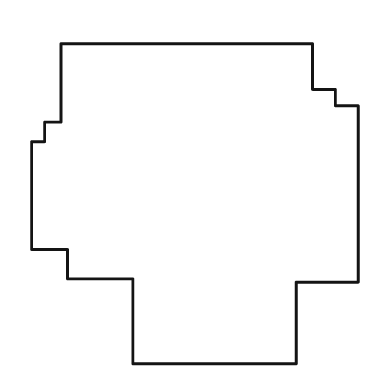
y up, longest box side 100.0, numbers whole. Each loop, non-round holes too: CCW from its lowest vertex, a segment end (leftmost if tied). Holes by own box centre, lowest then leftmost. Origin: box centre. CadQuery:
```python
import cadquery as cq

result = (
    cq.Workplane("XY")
    .moveTo(-19.0, -49.0)
    .lineTo(31.0, -49.0)
    .lineTo(31.0, -24.0)
    .lineTo(50.0, -24.0)
    .lineTo(50.0, 30.0)
    .lineTo(43.0, 30.0)
    .lineTo(43.0, 35.0)
    .lineTo(36.0, 35.0)
    .lineTo(36.0, 49.0)
    .lineTo(-41.0, 49.0)
    .lineTo(-41.0, 25.0)
    .lineTo(-46.0, 25.0)
    .lineTo(-46.0, 19.0)
    .lineTo(-50.0, 19.0)
    .lineTo(-50.0, -14.0)
    .lineTo(-39.0, -14.0)
    .lineTo(-39.0, -23.0)
    .lineTo(-19.0, -23.0)
    .close()
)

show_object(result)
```